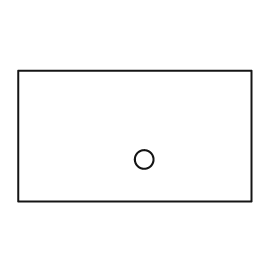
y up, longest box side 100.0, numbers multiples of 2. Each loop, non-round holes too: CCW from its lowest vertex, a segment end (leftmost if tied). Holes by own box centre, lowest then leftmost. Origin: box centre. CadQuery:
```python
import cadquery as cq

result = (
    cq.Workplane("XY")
    .moveTo(-50.0, -28.0)
    .lineTo(50.0, -28.0)
    .lineTo(50.0, 28.0)
    .lineTo(-50.0, 28.0)
    .close()
    .moveTo(4.0, -10.0)
    .circle(4.0)
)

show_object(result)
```